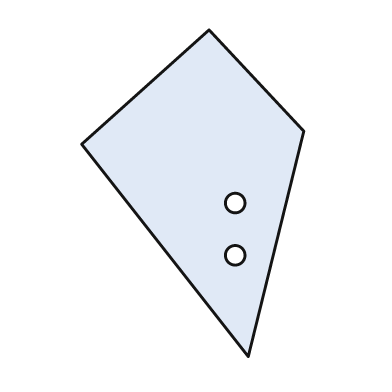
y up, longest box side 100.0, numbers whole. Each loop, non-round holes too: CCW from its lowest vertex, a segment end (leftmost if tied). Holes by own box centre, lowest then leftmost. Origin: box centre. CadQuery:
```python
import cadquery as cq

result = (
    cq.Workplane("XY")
    .moveTo(17.0, -50.0)
    .lineTo(34.0, 19.0)
    .lineTo(5.0, 50.0)
    .lineTo(-34.0, 15.0)
    .close()
    .moveTo(13.0, -19.0)
    .circle(3.0)
    .moveTo(13.0, -3.0)
    .circle(3.0)
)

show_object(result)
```